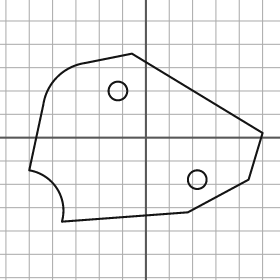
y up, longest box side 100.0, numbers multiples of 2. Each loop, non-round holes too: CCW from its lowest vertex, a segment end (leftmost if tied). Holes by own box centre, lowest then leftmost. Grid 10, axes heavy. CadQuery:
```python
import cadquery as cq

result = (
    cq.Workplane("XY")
    .moveTo(-36.0, -36.0)
    .lineTo(18.0, -32.0)
    .lineTo(44.0, -18.0)
    .lineTo(50.0, 2.0)
    .lineTo(-6.0, 36.0)
    .lineTo(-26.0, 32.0)
    .threePointArc((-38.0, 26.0), (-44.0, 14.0))
    .lineTo(-50.0, -14.0)
    .threePointArc((-38.0, -22.0), (-36.0, -36.0))
    .close()
    .moveTo(22.0, -18.0)
    .circle(4.0)
    .moveTo(-12.0, 20.0)
    .circle(4.0)
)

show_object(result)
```